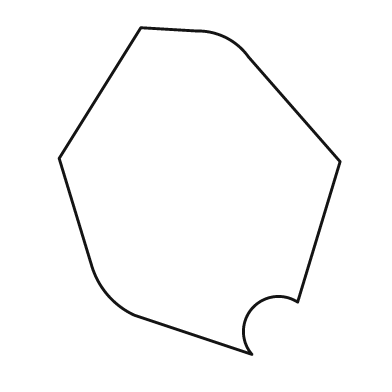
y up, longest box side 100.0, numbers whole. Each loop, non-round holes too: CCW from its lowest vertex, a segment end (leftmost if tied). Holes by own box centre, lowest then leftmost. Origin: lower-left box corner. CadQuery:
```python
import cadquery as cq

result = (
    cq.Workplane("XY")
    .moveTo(59.0, 0.0)
    .threePointArc((59.0, 14.0), (73.0, 16.0))
    .lineTo(86.0, 59.0)
    .lineTo(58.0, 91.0)
    .threePointArc((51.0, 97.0), (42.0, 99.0))
    .lineTo(25.0, 100.0)
    .lineTo(0.0, 60.0)
    .lineTo(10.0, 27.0)
    .threePointArc((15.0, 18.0), (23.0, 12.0))
    .close()
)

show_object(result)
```